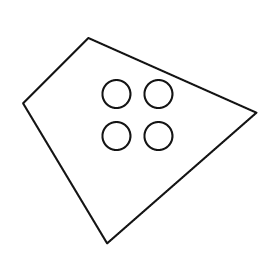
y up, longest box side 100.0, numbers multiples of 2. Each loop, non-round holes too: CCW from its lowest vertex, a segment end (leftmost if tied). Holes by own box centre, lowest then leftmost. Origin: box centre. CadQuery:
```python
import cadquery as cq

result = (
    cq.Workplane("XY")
    .moveTo(-14.0, -44.0)
    .lineTo(50.0, 12.0)
    .lineTo(-22.0, 44.0)
    .lineTo(-50.0, 16.0)
    .close()
    .moveTo(-10.0, 2.0)
    .circle(6.0)
    .moveTo(8.0, 2.0)
    .circle(6.0)
    .moveTo(-10.0, 20.0)
    .circle(6.0)
    .moveTo(8.0, 20.0)
    .circle(6.0)
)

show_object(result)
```